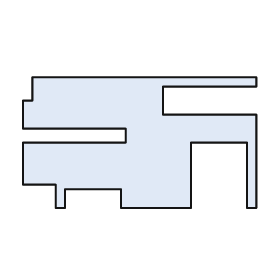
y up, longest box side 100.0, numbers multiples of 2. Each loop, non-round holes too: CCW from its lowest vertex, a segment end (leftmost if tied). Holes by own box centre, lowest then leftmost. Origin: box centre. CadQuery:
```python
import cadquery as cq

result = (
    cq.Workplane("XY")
    .moveTo(-36.0, -28.0)
    .lineTo(-32.0, -28.0)
    .lineTo(-32.0, -20.0)
    .lineTo(-8.0, -20.0)
    .lineTo(-8.0, -28.0)
    .lineTo(22.0, -28.0)
    .lineTo(22.0, 0.0)
    .lineTo(46.0, 0.0)
    .lineTo(46.0, -28.0)
    .lineTo(50.0, -28.0)
    .lineTo(50.0, 12.0)
    .lineTo(10.0, 12.0)
    .lineTo(10.0, 24.0)
    .lineTo(50.0, 24.0)
    .lineTo(50.0, 28.0)
    .lineTo(-46.0, 28.0)
    .lineTo(-46.0, 18.0)
    .lineTo(-50.0, 18.0)
    .lineTo(-50.0, 6.0)
    .lineTo(-6.0, 6.0)
    .lineTo(-6.0, 0.0)
    .lineTo(-50.0, 0.0)
    .lineTo(-50.0, -18.0)
    .lineTo(-36.0, -18.0)
    .close()
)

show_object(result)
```